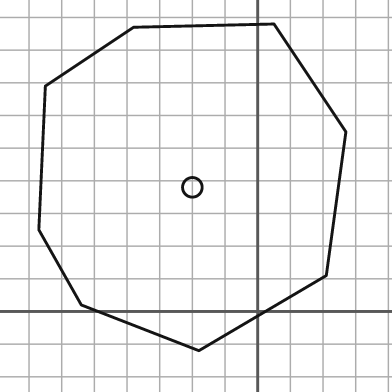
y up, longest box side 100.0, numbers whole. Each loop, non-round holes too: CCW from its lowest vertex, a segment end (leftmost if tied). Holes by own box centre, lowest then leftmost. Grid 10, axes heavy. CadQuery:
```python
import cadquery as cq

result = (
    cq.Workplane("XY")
    .moveTo(-18.0, -12.0)
    .lineTo(21.0, 11.0)
    .lineTo(27.0, 55.0)
    .lineTo(5.0, 88.0)
    .lineTo(-38.0, 87.0)
    .lineTo(-65.0, 69.0)
    .lineTo(-67.0, 25.0)
    .lineTo(-54.0, 2.0)
    .close()
    .moveTo(-20.0, 38.0)
    .circle(3.0)
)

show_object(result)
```